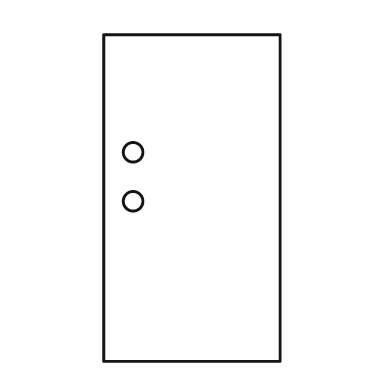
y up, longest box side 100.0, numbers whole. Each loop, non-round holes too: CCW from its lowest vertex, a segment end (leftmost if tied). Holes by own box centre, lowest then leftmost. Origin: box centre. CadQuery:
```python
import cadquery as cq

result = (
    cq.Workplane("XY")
    .moveTo(-27.0, -50.0)
    .lineTo(27.0, -50.0)
    .lineTo(27.0, 50.0)
    .lineTo(-27.0, 50.0)
    .close()
    .moveTo(-18.0, -1.0)
    .circle(3.0)
    .moveTo(-18.0, 14.0)
    .circle(3.0)
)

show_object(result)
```